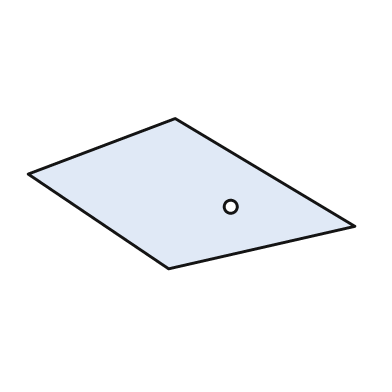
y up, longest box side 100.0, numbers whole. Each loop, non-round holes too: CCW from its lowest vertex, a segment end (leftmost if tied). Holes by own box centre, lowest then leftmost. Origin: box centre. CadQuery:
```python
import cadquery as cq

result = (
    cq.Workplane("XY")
    .moveTo(-7.0, -23.0)
    .lineTo(50.0, -10.0)
    .lineTo(-5.0, 23.0)
    .lineTo(-50.0, 6.0)
    .close()
    .moveTo(12.0, -4.0)
    .circle(2.0)
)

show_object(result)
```